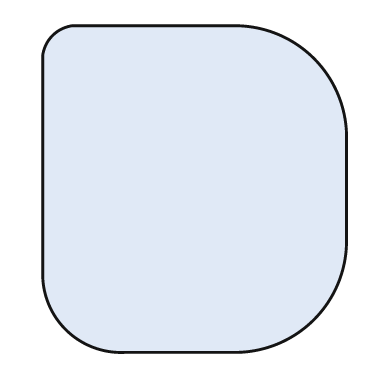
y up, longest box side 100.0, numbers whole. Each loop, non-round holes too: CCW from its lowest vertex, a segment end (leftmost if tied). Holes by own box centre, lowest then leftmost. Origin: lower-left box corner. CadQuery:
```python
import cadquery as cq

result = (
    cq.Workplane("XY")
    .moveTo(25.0, 0.0)
    .lineTo(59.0, 0.0)
    .threePointArc((83.0, 10.0), (93.0, 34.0))
    .lineTo(93.0, 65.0)
    .threePointArc((83.0, 90.0), (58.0, 100.0))
    .lineTo(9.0, 100.0)
    .threePointArc((3.0, 97.0), (0.0, 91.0))
    .lineTo(0.0, 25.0)
    .threePointArc((7.0, 7.0), (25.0, 0.0))
    .close()
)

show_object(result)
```